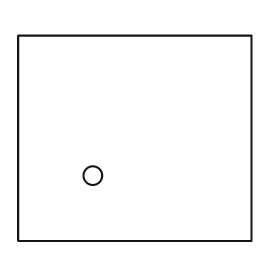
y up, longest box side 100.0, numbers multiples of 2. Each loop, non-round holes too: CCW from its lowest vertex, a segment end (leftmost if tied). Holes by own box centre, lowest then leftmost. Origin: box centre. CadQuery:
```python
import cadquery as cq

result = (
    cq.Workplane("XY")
    .moveTo(-50.0, -44.0)
    .lineTo(50.0, -44.0)
    .lineTo(50.0, 44.0)
    .lineTo(-50.0, 44.0)
    .close()
    .moveTo(-18.0, -16.0)
    .circle(4.0)
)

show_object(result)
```